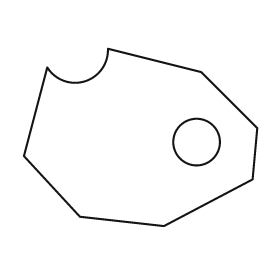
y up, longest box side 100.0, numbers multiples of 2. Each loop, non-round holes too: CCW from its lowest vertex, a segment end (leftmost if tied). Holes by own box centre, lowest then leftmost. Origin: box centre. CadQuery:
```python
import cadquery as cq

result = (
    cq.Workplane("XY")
    .moveTo(10.0, -38.0)
    .lineTo(48.0, -18.0)
    .lineTo(50.0, 4.0)
    .lineTo(26.0, 28.0)
    .lineTo(-14.0, 38.0)
    .threePointArc((-24.0, 24.0), (-40.0, 30.0))
    .lineTo(-50.0, -8.0)
    .lineTo(-26.0, -34.0)
    .close()
    .moveTo(24.0, -2.0)
    .circle(10.0)
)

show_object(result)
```